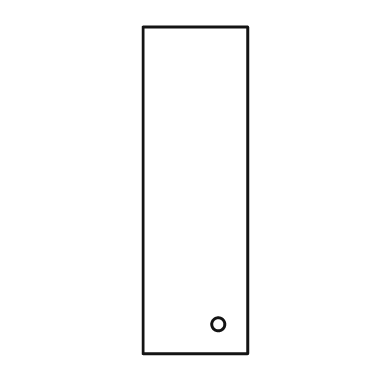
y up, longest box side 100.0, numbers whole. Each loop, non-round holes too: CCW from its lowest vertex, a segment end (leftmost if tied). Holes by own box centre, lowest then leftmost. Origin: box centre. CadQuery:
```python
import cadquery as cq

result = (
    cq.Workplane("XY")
    .moveTo(-16.0, -50.0)
    .lineTo(16.0, -50.0)
    .lineTo(16.0, 50.0)
    .lineTo(-16.0, 50.0)
    .close()
    .moveTo(7.0, -41.0)
    .circle(2.0)
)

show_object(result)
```